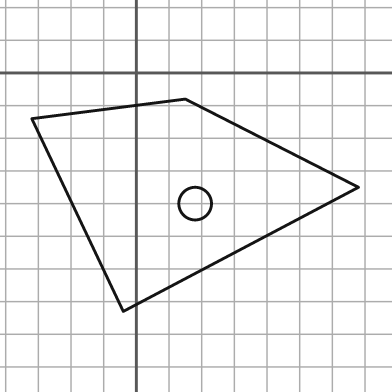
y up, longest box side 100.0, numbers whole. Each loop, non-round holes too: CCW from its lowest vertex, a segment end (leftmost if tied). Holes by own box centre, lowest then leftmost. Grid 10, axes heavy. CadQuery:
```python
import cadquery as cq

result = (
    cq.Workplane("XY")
    .moveTo(-4.0, -73.0)
    .lineTo(68.0, -35.0)
    .lineTo(15.0, -8.0)
    .lineTo(-32.0, -14.0)
    .close()
    .moveTo(18.0, -40.0)
    .circle(5.0)
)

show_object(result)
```